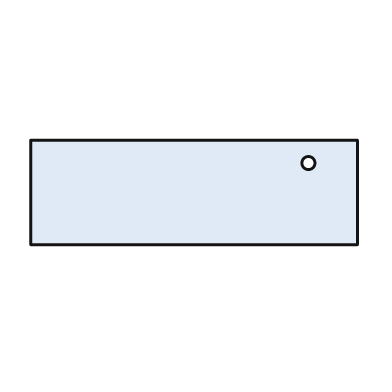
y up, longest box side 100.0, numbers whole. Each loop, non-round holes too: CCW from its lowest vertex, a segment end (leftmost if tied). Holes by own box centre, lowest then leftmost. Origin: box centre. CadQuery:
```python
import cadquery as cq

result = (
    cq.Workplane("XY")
    .moveTo(-50.0, -16.0)
    .lineTo(50.0, -16.0)
    .lineTo(50.0, 16.0)
    .lineTo(-50.0, 16.0)
    .close()
    .moveTo(35.0, 9.0)
    .circle(2.0)
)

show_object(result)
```